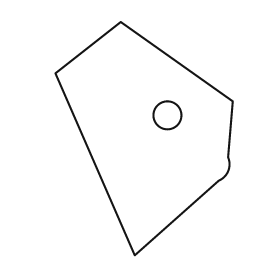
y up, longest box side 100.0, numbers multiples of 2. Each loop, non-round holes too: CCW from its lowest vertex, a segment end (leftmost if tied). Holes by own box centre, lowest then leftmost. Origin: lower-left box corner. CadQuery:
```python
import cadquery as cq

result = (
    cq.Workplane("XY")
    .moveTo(34.0, 0.0)
    .lineTo(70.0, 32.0)
    .threePointArc((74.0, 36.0), (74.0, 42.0))
    .lineTo(76.0, 66.0)
    .lineTo(28.0, 100.0)
    .lineTo(0.0, 78.0)
    .close()
    .moveTo(48.0, 60.0)
    .circle(6.0)
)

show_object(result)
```